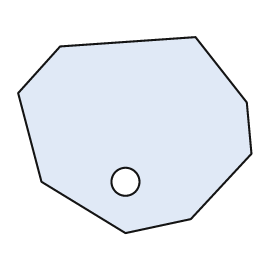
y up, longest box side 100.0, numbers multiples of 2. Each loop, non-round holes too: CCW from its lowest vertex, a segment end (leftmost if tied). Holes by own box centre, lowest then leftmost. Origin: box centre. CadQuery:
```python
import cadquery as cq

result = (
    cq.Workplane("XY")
    .moveTo(-4.0, -42.0)
    .lineTo(24.0, -36.0)
    .lineTo(50.0, -8.0)
    .lineTo(48.0, 14.0)
    .lineTo(26.0, 42.0)
    .lineTo(-32.0, 38.0)
    .lineTo(-50.0, 18.0)
    .lineTo(-40.0, -20.0)
    .close()
    .moveTo(-4.0, -20.0)
    .circle(6.0)
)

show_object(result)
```